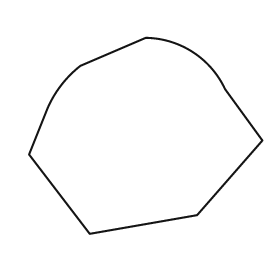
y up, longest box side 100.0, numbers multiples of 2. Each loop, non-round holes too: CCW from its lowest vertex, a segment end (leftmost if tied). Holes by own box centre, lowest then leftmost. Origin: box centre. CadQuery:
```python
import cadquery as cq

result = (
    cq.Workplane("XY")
    .moveTo(-24.0, -42.0)
    .lineTo(22.0, -34.0)
    .lineTo(50.0, -2.0)
    .lineTo(34.0, 20.0)
    .threePointArc((20.0, 36.0), (0.0, 42.0))
    .lineTo(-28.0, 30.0)
    .threePointArc((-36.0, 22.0), (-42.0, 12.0))
    .lineTo(-50.0, -8.0)
    .close()
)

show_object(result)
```